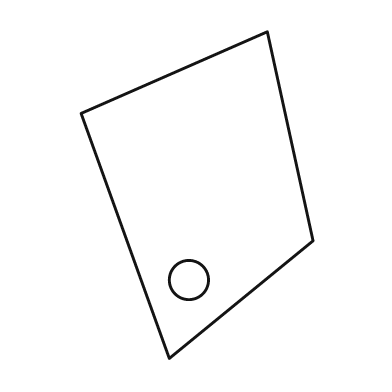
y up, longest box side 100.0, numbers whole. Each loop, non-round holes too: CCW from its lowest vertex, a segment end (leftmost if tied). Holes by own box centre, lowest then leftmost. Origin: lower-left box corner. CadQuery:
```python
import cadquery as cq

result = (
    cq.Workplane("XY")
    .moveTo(27.0, 0.0)
    .lineTo(71.0, 36.0)
    .lineTo(57.0, 100.0)
    .lineTo(0.0, 75.0)
    .close()
    .moveTo(33.0, 24.0)
    .circle(6.0)
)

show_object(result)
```